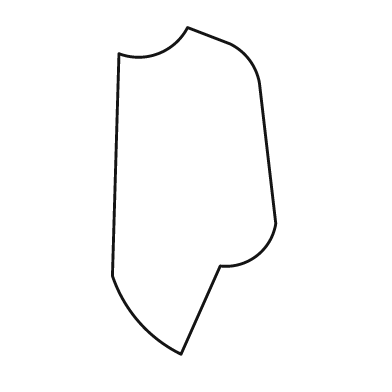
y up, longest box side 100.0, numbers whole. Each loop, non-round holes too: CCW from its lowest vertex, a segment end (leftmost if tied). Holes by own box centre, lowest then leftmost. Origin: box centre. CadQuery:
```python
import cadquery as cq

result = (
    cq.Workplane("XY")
    .moveTo(-4.0, -50.0)
    .lineTo(8.0, -23.0)
    .threePointArc((19.0, -20.0), (25.0, -10.0))
    .lineTo(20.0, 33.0)
    .threePointArc((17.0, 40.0), (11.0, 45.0))
    .lineTo(-2.0, 50.0)
    .threePointArc((-11.0, 42.0), (-23.0, 42.0))
    .lineTo(-25.0, -26.0)
    .threePointArc((-17.0, -40.0), (-4.0, -50.0))
    .close()
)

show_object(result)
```